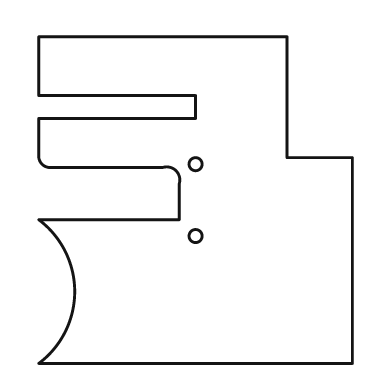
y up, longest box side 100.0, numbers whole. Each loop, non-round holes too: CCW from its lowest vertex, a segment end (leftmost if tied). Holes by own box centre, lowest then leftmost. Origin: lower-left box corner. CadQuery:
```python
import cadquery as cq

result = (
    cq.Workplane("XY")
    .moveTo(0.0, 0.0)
    .lineTo(96.0, 0.0)
    .lineTo(96.0, 63.0)
    .lineTo(76.0, 63.0)
    .lineTo(76.0, 100.0)
    .lineTo(0.0, 100.0)
    .lineTo(0.0, 82.0)
    .lineTo(48.0, 82.0)
    .lineTo(48.0, 75.0)
    .lineTo(0.0, 75.0)
    .lineTo(0.0, 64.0)
    .threePointArc((1.0, 61.0), (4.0, 60.0))
    .lineTo(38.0, 60.0)
    .threePointArc((42.0, 59.0), (43.0, 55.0))
    .lineTo(43.0, 44.0)
    .lineTo(0.0, 44.0)
    .threePointArc((11.0, 22.0), (0.0, 0.0))
    .close()
    .moveTo(48.0, 39.0)
    .circle(2.0)
    .moveTo(48.0, 61.0)
    .circle(2.0)
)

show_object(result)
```